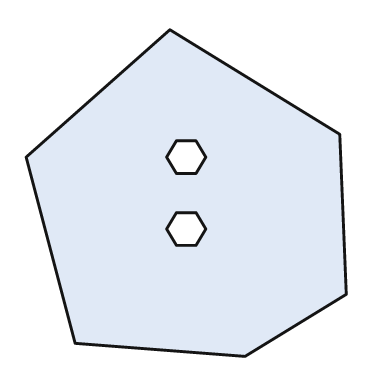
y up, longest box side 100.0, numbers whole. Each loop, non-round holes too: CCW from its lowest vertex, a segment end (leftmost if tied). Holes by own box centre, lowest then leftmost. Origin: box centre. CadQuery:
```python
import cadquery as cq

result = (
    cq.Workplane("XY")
    .moveTo(18.0, -50.0)
    .lineTo(49.0, -31.0)
    .lineTo(47.0, 18.0)
    .lineTo(-5.0, 50.0)
    .lineTo(-49.0, 11.0)
    .lineTo(-34.0, -46.0)
    .close()
    .moveTo(-3.0, -16.0)
    .lineTo(3.0, -16.0)
    .lineTo(6.0, -11.0)
    .lineTo(3.0, -6.0)
    .lineTo(-3.0, -6.0)
    .lineTo(-6.0, -11.0)
    .close()
    .moveTo(-3.0, 6.0)
    .lineTo(3.0, 6.0)
    .lineTo(6.0, 11.0)
    .lineTo(3.0, 16.0)
    .lineTo(-3.0, 16.0)
    .lineTo(-6.0, 11.0)
    .close()
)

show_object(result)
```